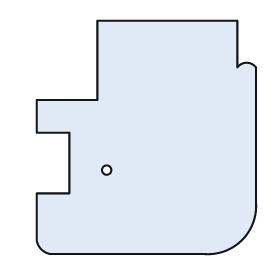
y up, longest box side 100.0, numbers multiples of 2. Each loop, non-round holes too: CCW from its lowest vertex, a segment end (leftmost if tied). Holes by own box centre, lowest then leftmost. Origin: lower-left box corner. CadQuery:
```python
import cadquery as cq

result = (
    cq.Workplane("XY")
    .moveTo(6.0, 0.0)
    .lineTo(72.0, 0.0)
    .threePointArc((88.0, 6.0), (94.0, 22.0))
    .lineTo(94.0, 80.0)
    .threePointArc((90.0, 82.0), (86.0, 80.0))
    .lineTo(86.0, 100.0)
    .lineTo(26.0, 100.0)
    .lineTo(26.0, 66.0)
    .lineTo(0.0, 66.0)
    .lineTo(0.0, 52.0)
    .lineTo(14.0, 52.0)
    .lineTo(14.0, 26.0)
    .lineTo(0.0, 26.0)
    .lineTo(0.0, 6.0)
    .threePointArc((2.0, 2.0), (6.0, 0.0))
    .close()
    .moveTo(30.0, 36.0)
    .circle(2.0)
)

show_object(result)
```